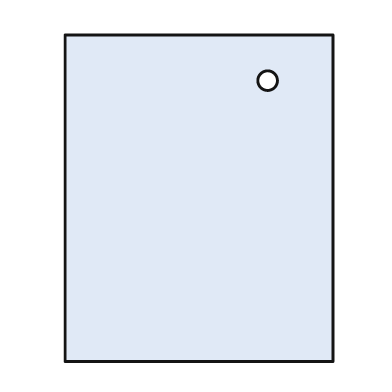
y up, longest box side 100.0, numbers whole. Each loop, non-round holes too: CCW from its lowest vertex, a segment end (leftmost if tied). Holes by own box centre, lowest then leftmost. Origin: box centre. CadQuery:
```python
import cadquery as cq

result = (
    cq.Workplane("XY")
    .moveTo(-41.0, -50.0)
    .lineTo(41.0, -50.0)
    .lineTo(41.0, 50.0)
    .lineTo(-41.0, 50.0)
    .close()
    .moveTo(21.0, 36.0)
    .circle(3.0)
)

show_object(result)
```